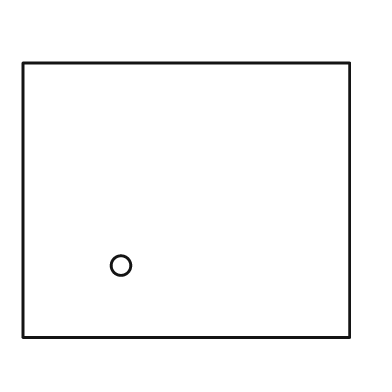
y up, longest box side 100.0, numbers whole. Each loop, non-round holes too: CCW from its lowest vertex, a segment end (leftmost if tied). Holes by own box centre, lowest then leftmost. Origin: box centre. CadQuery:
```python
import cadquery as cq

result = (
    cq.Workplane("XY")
    .moveTo(-50.0, -42.0)
    .lineTo(50.0, -42.0)
    .lineTo(50.0, 42.0)
    .lineTo(-50.0, 42.0)
    .close()
    .moveTo(-20.0, -20.0)
    .circle(3.0)
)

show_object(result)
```